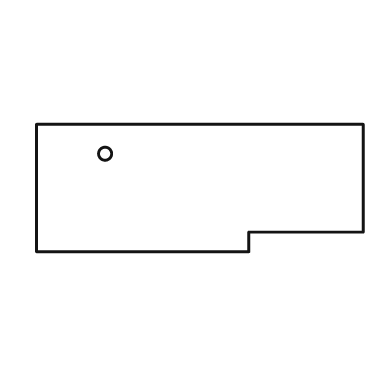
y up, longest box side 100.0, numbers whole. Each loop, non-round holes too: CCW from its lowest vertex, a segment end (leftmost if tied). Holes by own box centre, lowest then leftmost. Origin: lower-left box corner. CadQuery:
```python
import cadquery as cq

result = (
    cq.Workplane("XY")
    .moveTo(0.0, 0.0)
    .lineTo(65.0, 0.0)
    .lineTo(65.0, 6.0)
    .lineTo(100.0, 6.0)
    .lineTo(100.0, 39.0)
    .lineTo(0.0, 39.0)
    .close()
    .moveTo(21.0, 30.0)
    .circle(2.0)
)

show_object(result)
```